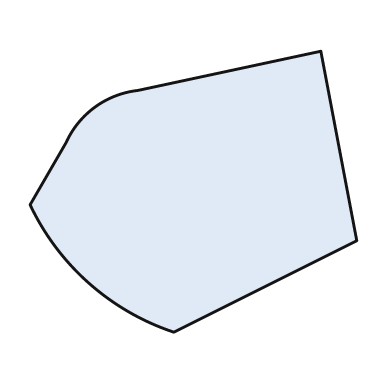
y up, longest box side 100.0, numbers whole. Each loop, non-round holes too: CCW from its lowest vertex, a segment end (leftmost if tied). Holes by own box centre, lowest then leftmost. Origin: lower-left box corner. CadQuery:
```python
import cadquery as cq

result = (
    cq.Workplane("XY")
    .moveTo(44.0, 0.0)
    .lineTo(100.0, 28.0)
    .lineTo(89.0, 86.0)
    .lineTo(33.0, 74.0)
    .threePointArc((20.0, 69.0), (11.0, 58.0))
    .lineTo(0.0, 39.0)
    .threePointArc((18.0, 15.0), (44.0, 0.0))
    .close()
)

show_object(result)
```